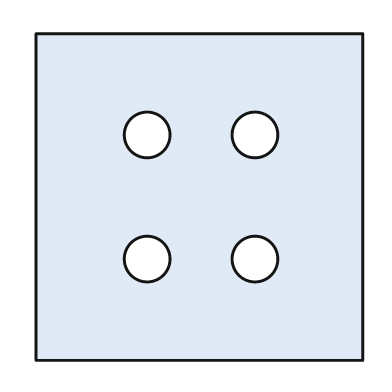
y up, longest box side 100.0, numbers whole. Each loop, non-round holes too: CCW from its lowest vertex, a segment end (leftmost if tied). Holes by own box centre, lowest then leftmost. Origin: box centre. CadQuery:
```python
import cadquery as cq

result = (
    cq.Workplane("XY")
    .moveTo(-50.0, -50.0)
    .lineTo(50.0, -50.0)
    .lineTo(50.0, 50.0)
    .lineTo(-50.0, 50.0)
    .close()
    .moveTo(-16.0, -19.0)
    .circle(7.0)
    .moveTo(17.0, -19.0)
    .circle(7.0)
    .moveTo(-16.0, 19.0)
    .circle(7.0)
    .moveTo(17.0, 19.0)
    .circle(7.0)
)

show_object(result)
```